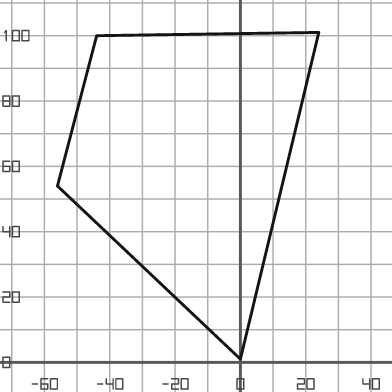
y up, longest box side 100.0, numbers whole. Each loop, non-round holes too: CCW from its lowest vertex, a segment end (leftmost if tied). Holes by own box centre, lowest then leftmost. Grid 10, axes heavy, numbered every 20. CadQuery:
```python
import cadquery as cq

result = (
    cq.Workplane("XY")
    .moveTo(0.0, 1.0)
    .lineTo(24.0, 101.0)
    .lineTo(-44.0, 100.0)
    .lineTo(-56.0, 54.0)
    .close()
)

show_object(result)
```